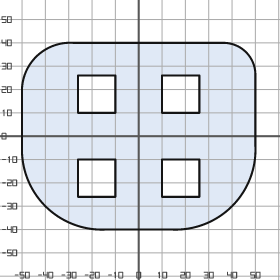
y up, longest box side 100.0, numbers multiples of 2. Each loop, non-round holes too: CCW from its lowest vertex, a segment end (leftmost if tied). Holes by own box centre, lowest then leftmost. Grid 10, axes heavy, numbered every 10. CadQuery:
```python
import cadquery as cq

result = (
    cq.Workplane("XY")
    .moveTo(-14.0, -40.0)
    .lineTo(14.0, -40.0)
    .threePointArc((40.0, -30.0), (50.0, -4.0))
    .lineTo(50.0, 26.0)
    .threePointArc((46.0, 36.0), (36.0, 40.0))
    .lineTo(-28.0, 40.0)
    .threePointArc((-44.0, 34.0), (-50.0, 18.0))
    .lineTo(-50.0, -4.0)
    .threePointArc((-40.0, -30.0), (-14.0, -40.0))
    .close()
    .moveTo(-26.0, -26.0)
    .lineTo(-10.0, -26.0)
    .lineTo(-10.0, -10.0)
    .lineTo(-26.0, -10.0)
    .close()
    .moveTo(10.0, -26.0)
    .lineTo(26.0, -26.0)
    .lineTo(26.0, -10.0)
    .lineTo(10.0, -10.0)
    .close()
    .moveTo(-26.0, 10.0)
    .lineTo(-10.0, 10.0)
    .lineTo(-10.0, 26.0)
    .lineTo(-26.0, 26.0)
    .close()
    .moveTo(10.0, 10.0)
    .lineTo(26.0, 10.0)
    .lineTo(26.0, 26.0)
    .lineTo(10.0, 26.0)
    .close()
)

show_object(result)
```